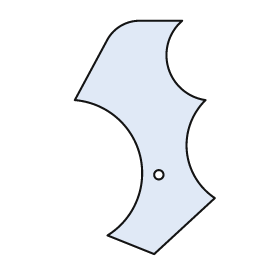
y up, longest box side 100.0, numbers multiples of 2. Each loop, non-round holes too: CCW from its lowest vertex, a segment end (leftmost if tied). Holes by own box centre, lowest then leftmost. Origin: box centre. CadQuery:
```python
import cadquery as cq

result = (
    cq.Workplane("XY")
    .moveTo(4.0, -50.0)
    .lineTo(30.0, -26.0)
    .threePointArc((18.0, -6.0), (26.0, 16.0))
    .threePointArc((10.0, 30.0), (16.0, 50.0))
    .lineTo(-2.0, 50.0)
    .threePointArc((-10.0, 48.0), (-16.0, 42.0))
    .lineTo(-30.0, 16.0)
    .threePointArc((-2.0, -8.0), (-16.0, -42.0))
    .close()
    .moveTo(6.0, -16.0)
    .circle(2.0)
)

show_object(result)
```